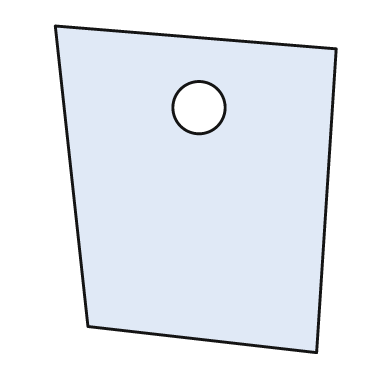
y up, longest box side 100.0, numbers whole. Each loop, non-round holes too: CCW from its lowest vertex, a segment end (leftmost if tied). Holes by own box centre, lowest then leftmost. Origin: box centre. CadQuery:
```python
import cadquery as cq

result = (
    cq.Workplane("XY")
    .moveTo(37.0, -50.0)
    .lineTo(43.0, 43.0)
    .lineTo(-43.0, 50.0)
    .lineTo(-33.0, -42.0)
    .close()
    .moveTo(1.0, 25.0)
    .circle(8.0)
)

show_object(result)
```